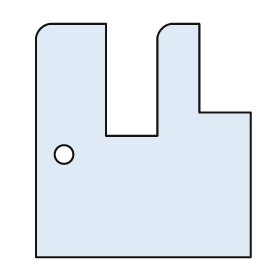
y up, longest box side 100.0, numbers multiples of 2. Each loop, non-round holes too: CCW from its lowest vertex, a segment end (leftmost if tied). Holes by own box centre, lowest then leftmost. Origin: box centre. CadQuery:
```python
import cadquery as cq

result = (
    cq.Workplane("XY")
    .moveTo(-46.0, -50.0)
    .lineTo(46.0, -50.0)
    .lineTo(46.0, 12.0)
    .lineTo(24.0, 12.0)
    .lineTo(24.0, 50.0)
    .lineTo(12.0, 50.0)
    .threePointArc((8.0, 48.0), (6.0, 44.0))
    .lineTo(6.0, 2.0)
    .lineTo(-16.0, 2.0)
    .lineTo(-16.0, 50.0)
    .lineTo(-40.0, 50.0)
    .threePointArc((-44.0, 48.0), (-46.0, 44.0))
    .close()
    .moveTo(-34.0, -6.0)
    .circle(4.0)
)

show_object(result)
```